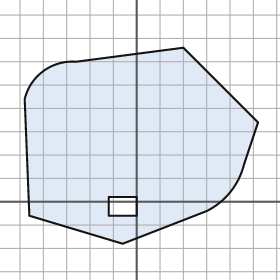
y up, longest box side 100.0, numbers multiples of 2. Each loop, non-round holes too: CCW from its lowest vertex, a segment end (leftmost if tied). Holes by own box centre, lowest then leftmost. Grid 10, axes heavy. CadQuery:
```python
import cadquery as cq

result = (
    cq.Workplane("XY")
    .moveTo(-6.0, -18.0)
    .lineTo(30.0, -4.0)
    .threePointArc((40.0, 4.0), (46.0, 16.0))
    .lineTo(52.0, 34.0)
    .lineTo(20.0, 66.0)
    .lineTo(-26.0, 60.0)
    .threePointArc((-40.0, 56.0), (-48.0, 44.0))
    .lineTo(-46.0, -6.0)
    .close()
    .moveTo(-12.0, -6.0)
    .lineTo(0.0, -6.0)
    .lineTo(0.0, 2.0)
    .lineTo(-12.0, 2.0)
    .close()
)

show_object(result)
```